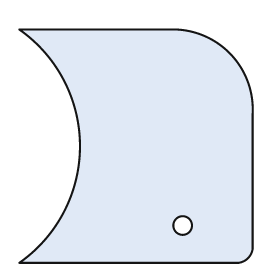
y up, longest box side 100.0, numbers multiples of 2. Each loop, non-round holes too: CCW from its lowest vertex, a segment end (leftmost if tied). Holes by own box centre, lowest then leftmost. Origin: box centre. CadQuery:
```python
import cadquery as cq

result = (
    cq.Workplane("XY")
    .moveTo(-50.0, -50.0)
    .lineTo(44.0, -50.0)
    .threePointArc((48.0, -48.0), (50.0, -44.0))
    .lineTo(50.0, 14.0)
    .threePointArc((40.0, 40.0), (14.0, 50.0))
    .lineTo(-50.0, 50.0)
    .threePointArc((-24.0, 0.0), (-50.0, -50.0))
    .close()
    .moveTo(20.0, -34.0)
    .circle(4.0)
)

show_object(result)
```